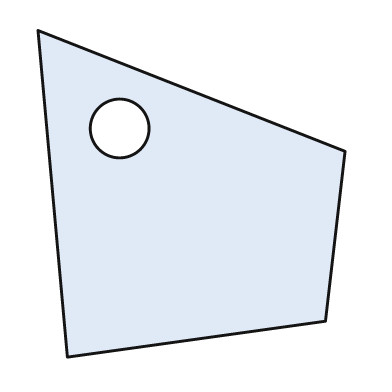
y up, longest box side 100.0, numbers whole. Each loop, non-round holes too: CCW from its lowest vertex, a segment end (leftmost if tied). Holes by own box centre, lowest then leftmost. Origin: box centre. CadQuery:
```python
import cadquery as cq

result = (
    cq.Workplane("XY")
    .moveTo(-38.0, -50.0)
    .lineTo(41.0, -39.0)
    .lineTo(47.0, 13.0)
    .lineTo(-47.0, 50.0)
    .close()
    .moveTo(-22.0, 20.0)
    .circle(9.0)
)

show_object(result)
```